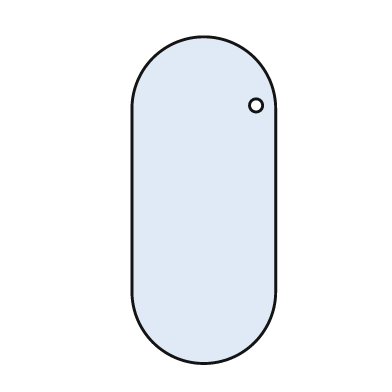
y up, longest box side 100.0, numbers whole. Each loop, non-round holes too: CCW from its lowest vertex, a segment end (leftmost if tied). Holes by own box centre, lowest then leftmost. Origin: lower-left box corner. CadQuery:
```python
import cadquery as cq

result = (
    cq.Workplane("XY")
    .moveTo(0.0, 22.0)
    .threePointArc((22.0, 0.0), (44.0, 22.0))
    .lineTo(44.0, 78.0)
    .threePointArc((22.0, 100.0), (0.0, 78.0))
    .close()
    .moveTo(38.0, 79.0)
    .circle(2.0)
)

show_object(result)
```